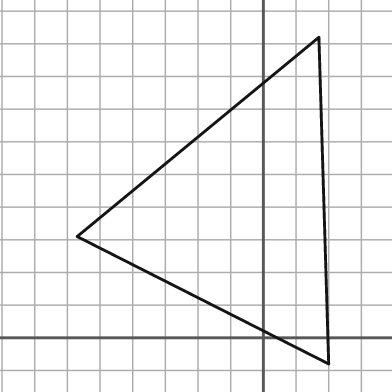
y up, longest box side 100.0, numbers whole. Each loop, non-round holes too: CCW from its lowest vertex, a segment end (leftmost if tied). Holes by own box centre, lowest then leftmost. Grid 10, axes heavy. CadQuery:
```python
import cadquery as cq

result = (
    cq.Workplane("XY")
    .moveTo(20.0, -8.0)
    .lineTo(17.0, 92.0)
    .lineTo(-57.0, 31.0)
    .close()
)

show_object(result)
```